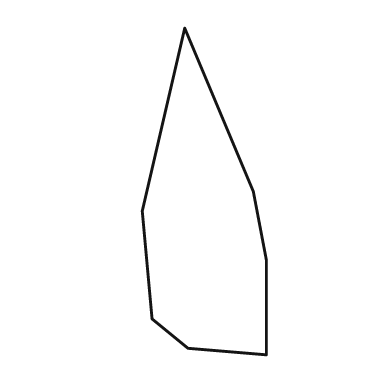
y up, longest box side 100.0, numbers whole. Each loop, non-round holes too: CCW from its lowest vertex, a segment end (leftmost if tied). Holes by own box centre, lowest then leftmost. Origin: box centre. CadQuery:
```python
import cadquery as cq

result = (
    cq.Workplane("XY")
    .moveTo(19.0, -50.0)
    .lineTo(19.0, -21.0)
    .lineTo(15.0, 0.0)
    .lineTo(-6.0, 50.0)
    .lineTo(-19.0, -6.0)
    .lineTo(-16.0, -39.0)
    .lineTo(-5.0, -48.0)
    .close()
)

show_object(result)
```